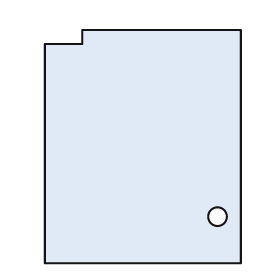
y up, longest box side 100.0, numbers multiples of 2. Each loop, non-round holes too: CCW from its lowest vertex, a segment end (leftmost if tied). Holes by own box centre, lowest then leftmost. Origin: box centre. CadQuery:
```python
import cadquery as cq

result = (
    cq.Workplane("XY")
    .moveTo(-42.0, -50.0)
    .lineTo(42.0, -50.0)
    .lineTo(42.0, 50.0)
    .lineTo(-26.0, 50.0)
    .lineTo(-26.0, 44.0)
    .lineTo(-42.0, 44.0)
    .close()
    .moveTo(32.0, -30.0)
    .circle(4.0)
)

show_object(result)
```